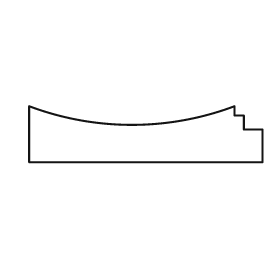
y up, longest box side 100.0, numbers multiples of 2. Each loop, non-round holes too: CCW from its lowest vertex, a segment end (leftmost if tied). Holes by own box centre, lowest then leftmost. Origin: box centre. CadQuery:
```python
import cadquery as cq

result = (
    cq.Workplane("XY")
    .moveTo(-50.0, -12.0)
    .lineTo(50.0, -12.0)
    .lineTo(50.0, 2.0)
    .lineTo(42.0, 2.0)
    .lineTo(42.0, 8.0)
    .lineTo(38.0, 8.0)
    .lineTo(38.0, 12.0)
    .threePointArc((-6.0, 4.0), (-50.0, 12.0))
    .close()
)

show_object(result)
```